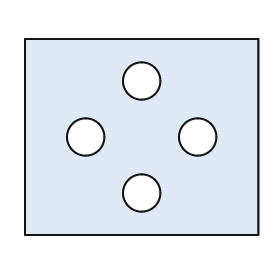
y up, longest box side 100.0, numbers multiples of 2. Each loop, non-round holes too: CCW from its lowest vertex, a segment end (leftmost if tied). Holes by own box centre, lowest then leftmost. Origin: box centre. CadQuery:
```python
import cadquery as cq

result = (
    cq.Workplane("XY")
    .moveTo(-50.0, -42.0)
    .lineTo(50.0, -42.0)
    .lineTo(50.0, 42.0)
    .lineTo(-50.0, 42.0)
    .close()
    .moveTo(0.0, -24.0)
    .circle(8.0)
    .moveTo(-24.0, 0.0)
    .circle(8.0)
    .moveTo(24.0, 0.0)
    .circle(8.0)
    .moveTo(0.0, 24.0)
    .circle(8.0)
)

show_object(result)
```